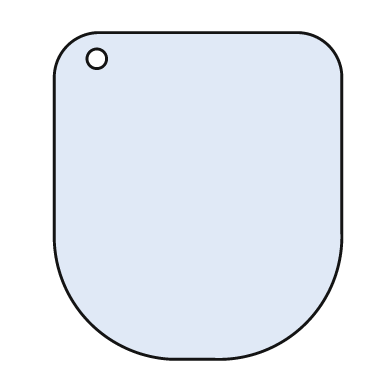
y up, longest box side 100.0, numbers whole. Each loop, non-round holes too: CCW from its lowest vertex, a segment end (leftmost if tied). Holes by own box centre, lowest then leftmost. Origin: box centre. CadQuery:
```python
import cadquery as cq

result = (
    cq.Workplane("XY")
    .moveTo(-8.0, -50.0)
    .lineTo(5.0, -50.0)
    .threePointArc((33.0, -39.0), (44.0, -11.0))
    .lineTo(44.0, 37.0)
    .threePointArc((40.0, 46.0), (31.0, 50.0))
    .lineTo(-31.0, 50.0)
    .threePointArc((-40.0, 46.0), (-44.0, 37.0))
    .lineTo(-44.0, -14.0)
    .threePointArc((-33.0, -39.0), (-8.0, -50.0))
    .close()
    .moveTo(-31.0, 42.0)
    .circle(3.0)
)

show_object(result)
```